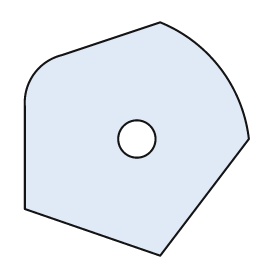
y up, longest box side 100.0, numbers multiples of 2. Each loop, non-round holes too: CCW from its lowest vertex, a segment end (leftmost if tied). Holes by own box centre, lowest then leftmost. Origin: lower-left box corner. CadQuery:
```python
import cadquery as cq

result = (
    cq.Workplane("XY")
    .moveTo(58.0, 0.0)
    .lineTo(96.0, 50.0)
    .threePointArc((84.0, 80.0), (58.0, 100.0))
    .lineTo(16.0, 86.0)
    .threePointArc((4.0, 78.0), (0.0, 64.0))
    .lineTo(0.0, 20.0)
    .close()
    .moveTo(48.0, 50.0)
    .circle(8.0)
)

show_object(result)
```